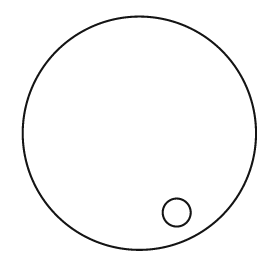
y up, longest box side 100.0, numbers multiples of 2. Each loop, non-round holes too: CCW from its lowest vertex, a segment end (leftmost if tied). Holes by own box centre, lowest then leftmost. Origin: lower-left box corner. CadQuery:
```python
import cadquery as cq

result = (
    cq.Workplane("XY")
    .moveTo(50.0, 50.0)
    .circle(50.0)
    .moveTo(66.0, 16.0)
    .circle(6.0)
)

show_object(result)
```